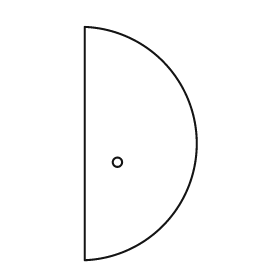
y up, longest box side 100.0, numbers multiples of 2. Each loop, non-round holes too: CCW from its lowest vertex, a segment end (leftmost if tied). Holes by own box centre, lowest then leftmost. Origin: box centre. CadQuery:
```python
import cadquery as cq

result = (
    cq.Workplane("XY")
    .moveTo(-24.0, -50.0)
    .threePointArc((24.0, 0.0), (-24.0, 50.0))
    .close()
    .moveTo(-10.0, -8.0)
    .circle(2.0)
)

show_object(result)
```